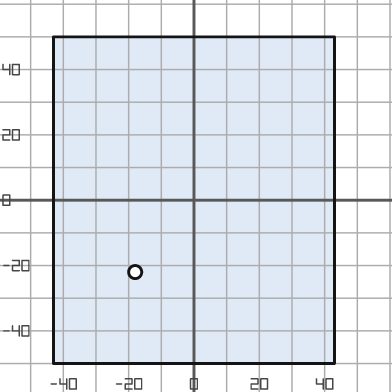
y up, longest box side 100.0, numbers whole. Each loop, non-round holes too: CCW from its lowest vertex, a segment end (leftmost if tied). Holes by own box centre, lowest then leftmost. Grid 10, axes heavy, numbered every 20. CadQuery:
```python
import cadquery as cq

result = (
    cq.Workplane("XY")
    .moveTo(-43.0, -50.0)
    .lineTo(43.0, -50.0)
    .lineTo(43.0, 50.0)
    .lineTo(-43.0, 50.0)
    .close()
    .moveTo(-18.0, -22.0)
    .circle(2.0)
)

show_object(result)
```